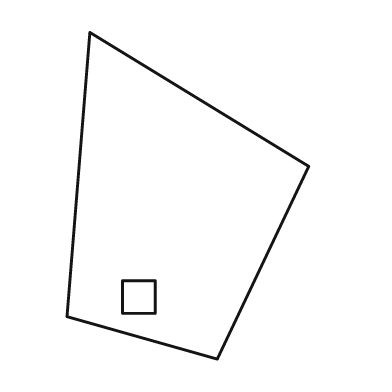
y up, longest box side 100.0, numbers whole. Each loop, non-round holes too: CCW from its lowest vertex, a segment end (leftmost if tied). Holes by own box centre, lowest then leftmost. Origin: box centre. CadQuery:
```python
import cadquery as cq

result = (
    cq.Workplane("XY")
    .moveTo(9.0, -50.0)
    .lineTo(37.0, 9.0)
    .lineTo(-30.0, 50.0)
    .lineTo(-37.0, -37.0)
    .close()
    .moveTo(-20.0, -36.0)
    .lineTo(-10.0, -36.0)
    .lineTo(-10.0, -26.0)
    .lineTo(-20.0, -26.0)
    .close()
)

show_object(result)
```